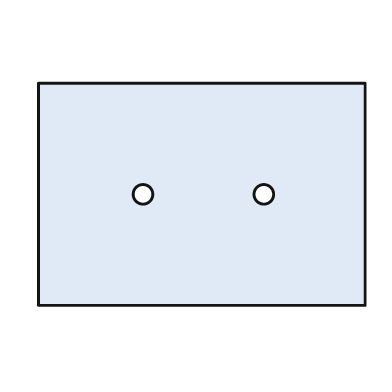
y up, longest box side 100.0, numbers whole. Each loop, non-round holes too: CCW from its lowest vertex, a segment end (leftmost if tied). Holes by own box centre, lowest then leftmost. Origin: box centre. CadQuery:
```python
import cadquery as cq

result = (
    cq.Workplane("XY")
    .moveTo(-50.0, -34.0)
    .lineTo(50.0, -34.0)
    .lineTo(50.0, 34.0)
    .lineTo(-50.0, 34.0)
    .close()
    .moveTo(-18.0, 0.0)
    .circle(3.0)
    .moveTo(19.0, 0.0)
    .circle(3.0)
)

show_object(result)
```